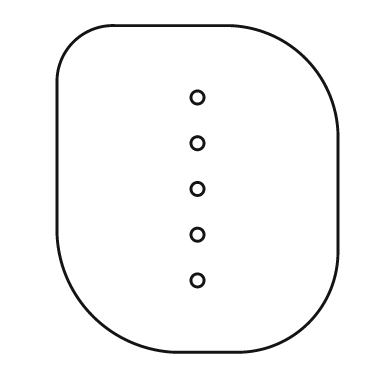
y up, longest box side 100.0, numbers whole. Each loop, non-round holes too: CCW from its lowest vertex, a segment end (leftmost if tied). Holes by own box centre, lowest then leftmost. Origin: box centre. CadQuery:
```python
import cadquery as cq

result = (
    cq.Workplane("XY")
    .moveTo(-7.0, -50.0)
    .lineTo(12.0, -50.0)
    .threePointArc((34.0, -41.0), (43.0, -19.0))
    .lineTo(43.0, 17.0)
    .threePointArc((33.0, 40.0), (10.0, 50.0))
    .lineTo(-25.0, 50.0)
    .threePointArc((-38.0, 45.0), (-43.0, 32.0))
    .lineTo(-43.0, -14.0)
    .threePointArc((-32.0, -39.0), (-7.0, -50.0))
    .close()
    .moveTo(0.0, -28.0)
    .circle(2.0)
    .moveTo(0.0, -14.0)
    .circle(2.0)
    .moveTo(0.0, 0.0)
    .circle(2.0)
    .moveTo(0.0, 14.0)
    .circle(2.0)
    .moveTo(0.0, 28.0)
    .circle(2.0)
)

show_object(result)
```